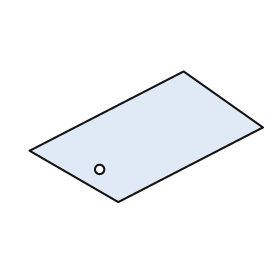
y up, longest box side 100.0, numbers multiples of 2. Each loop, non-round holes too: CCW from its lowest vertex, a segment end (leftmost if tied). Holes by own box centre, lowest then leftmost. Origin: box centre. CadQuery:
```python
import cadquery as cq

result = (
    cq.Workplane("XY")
    .moveTo(-12.0, -28.0)
    .lineTo(50.0, 4.0)
    .lineTo(16.0, 28.0)
    .lineTo(-50.0, -6.0)
    .close()
    .moveTo(-20.0, -14.0)
    .circle(2.0)
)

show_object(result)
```